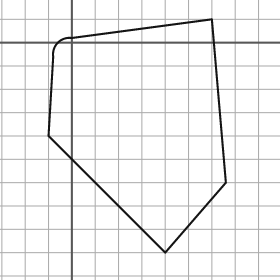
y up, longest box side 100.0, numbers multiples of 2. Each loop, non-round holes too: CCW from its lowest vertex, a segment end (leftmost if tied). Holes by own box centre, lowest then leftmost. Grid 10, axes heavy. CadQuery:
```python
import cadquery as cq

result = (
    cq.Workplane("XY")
    .moveTo(40.0, -90.0)
    .lineTo(66.0, -60.0)
    .lineTo(60.0, 10.0)
    .lineTo(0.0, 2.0)
    .threePointArc((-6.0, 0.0), (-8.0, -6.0))
    .lineTo(-10.0, -40.0)
    .close()
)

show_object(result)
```